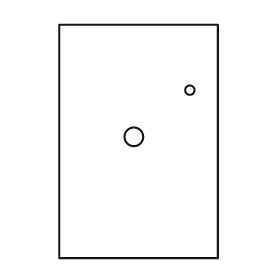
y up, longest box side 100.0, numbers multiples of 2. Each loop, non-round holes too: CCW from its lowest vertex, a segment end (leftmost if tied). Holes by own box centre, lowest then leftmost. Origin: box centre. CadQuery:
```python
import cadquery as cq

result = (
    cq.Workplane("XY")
    .moveTo(-34.0, -50.0)
    .lineTo(34.0, -50.0)
    .lineTo(34.0, 50.0)
    .lineTo(-34.0, 50.0)
    .close()
    .moveTo(-2.0, 2.0)
    .circle(4.0)
    .moveTo(22.0, 22.0)
    .circle(2.0)
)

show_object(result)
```